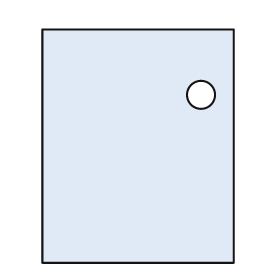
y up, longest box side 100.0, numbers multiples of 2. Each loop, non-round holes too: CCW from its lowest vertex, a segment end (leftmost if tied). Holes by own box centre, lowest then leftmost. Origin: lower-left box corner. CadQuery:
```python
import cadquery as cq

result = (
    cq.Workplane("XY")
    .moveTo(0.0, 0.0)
    .lineTo(82.0, 0.0)
    .lineTo(82.0, 100.0)
    .lineTo(0.0, 100.0)
    .close()
    .moveTo(68.0, 72.0)
    .circle(6.0)
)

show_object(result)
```